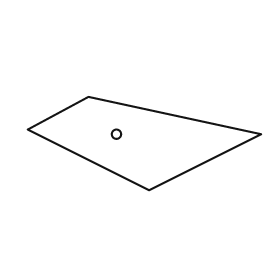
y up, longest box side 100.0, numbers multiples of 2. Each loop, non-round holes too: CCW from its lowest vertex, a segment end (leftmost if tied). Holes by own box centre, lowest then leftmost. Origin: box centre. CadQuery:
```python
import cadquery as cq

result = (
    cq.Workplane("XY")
    .moveTo(2.0, -20.0)
    .lineTo(50.0, 4.0)
    .lineTo(-24.0, 20.0)
    .lineTo(-50.0, 6.0)
    .close()
    .moveTo(-12.0, 4.0)
    .circle(2.0)
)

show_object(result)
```